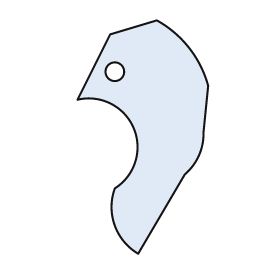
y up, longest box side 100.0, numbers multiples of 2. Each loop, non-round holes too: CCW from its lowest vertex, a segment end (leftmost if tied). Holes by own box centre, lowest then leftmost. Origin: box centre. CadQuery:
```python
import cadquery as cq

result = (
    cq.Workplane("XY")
    .moveTo(-2.0, -50.0)
    .lineTo(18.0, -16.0)
    .threePointArc((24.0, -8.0), (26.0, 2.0))
    .lineTo(28.0, 22.0)
    .threePointArc((20.0, 38.0), (6.0, 50.0))
    .lineTo(-14.0, 44.0)
    .lineTo(-28.0, 16.0)
    .threePointArc((-4.0, 4.0), (-12.0, -22.0))
    .threePointArc((-12.0, -38.0), (-2.0, -50.0))
    .close()
    .moveTo(-12.0, 28.0)
    .circle(4.0)
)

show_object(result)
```